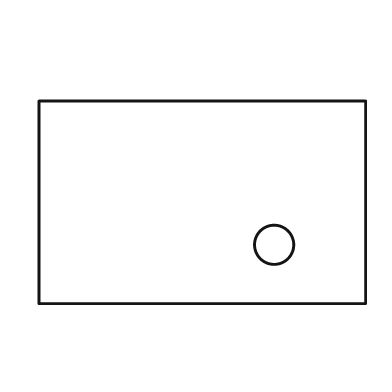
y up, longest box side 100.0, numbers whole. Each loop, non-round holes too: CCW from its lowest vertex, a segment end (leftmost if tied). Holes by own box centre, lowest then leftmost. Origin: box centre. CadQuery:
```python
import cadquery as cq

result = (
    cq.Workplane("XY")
    .moveTo(-50.0, -31.0)
    .lineTo(50.0, -31.0)
    .lineTo(50.0, 31.0)
    .lineTo(-50.0, 31.0)
    .close()
    .moveTo(22.0, -13.0)
    .circle(6.0)
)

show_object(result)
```